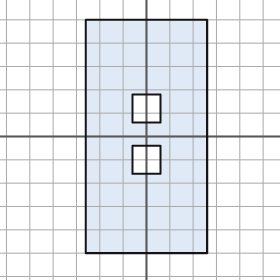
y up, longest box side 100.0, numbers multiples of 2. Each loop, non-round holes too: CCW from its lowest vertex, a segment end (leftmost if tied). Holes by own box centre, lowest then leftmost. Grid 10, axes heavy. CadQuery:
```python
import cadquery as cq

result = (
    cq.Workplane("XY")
    .moveTo(-26.0, -50.0)
    .lineTo(26.0, -50.0)
    .lineTo(26.0, 50.0)
    .lineTo(-26.0, 50.0)
    .close()
    .moveTo(-6.0, -16.0)
    .lineTo(6.0, -16.0)
    .lineTo(6.0, -4.0)
    .lineTo(-6.0, -4.0)
    .close()
    .moveTo(-6.0, 6.0)
    .lineTo(6.0, 6.0)
    .lineTo(6.0, 18.0)
    .lineTo(-6.0, 18.0)
    .close()
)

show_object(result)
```